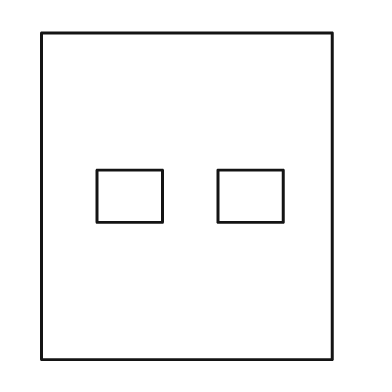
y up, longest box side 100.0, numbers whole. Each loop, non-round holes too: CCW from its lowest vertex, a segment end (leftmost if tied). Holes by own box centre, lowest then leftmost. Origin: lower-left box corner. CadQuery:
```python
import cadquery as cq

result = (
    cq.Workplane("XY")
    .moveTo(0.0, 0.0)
    .lineTo(89.0, 0.0)
    .lineTo(89.0, 100.0)
    .lineTo(0.0, 100.0)
    .close()
    .moveTo(17.0, 42.0)
    .lineTo(37.0, 42.0)
    .lineTo(37.0, 58.0)
    .lineTo(17.0, 58.0)
    .close()
    .moveTo(54.0, 42.0)
    .lineTo(74.0, 42.0)
    .lineTo(74.0, 58.0)
    .lineTo(54.0, 58.0)
    .close()
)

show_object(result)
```